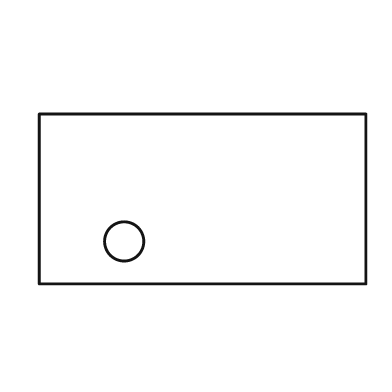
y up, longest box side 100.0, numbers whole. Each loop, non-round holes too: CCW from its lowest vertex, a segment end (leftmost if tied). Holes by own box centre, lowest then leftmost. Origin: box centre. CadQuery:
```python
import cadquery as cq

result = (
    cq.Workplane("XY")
    .moveTo(-50.0, -26.0)
    .lineTo(50.0, -26.0)
    .lineTo(50.0, 26.0)
    .lineTo(-50.0, 26.0)
    .close()
    .moveTo(-24.0, -13.0)
    .circle(6.0)
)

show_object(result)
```